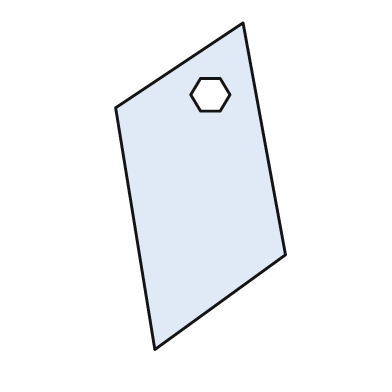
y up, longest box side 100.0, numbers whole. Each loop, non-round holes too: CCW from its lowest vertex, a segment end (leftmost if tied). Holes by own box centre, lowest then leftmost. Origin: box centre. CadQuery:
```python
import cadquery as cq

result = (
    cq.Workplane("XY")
    .moveTo(-14.0, -50.0)
    .lineTo(26.0, -21.0)
    .lineTo(13.0, 50.0)
    .lineTo(-26.0, 24.0)
    .close()
    .moveTo(0.0, 23.0)
    .lineTo(6.0, 23.0)
    .lineTo(9.0, 28.0)
    .lineTo(6.0, 33.0)
    .lineTo(0.0, 33.0)
    .lineTo(-3.0, 28.0)
    .close()
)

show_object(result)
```